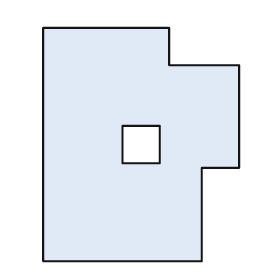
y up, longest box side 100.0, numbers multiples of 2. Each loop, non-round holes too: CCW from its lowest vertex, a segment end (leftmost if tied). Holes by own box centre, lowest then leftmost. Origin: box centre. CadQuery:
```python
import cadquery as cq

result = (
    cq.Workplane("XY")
    .moveTo(-42.0, -50.0)
    .lineTo(26.0, -50.0)
    .lineTo(26.0, -10.0)
    .lineTo(42.0, -10.0)
    .lineTo(42.0, 34.0)
    .lineTo(12.0, 34.0)
    .lineTo(12.0, 50.0)
    .lineTo(-42.0, 50.0)
    .close()
    .moveTo(-8.0, -8.0)
    .lineTo(8.0, -8.0)
    .lineTo(8.0, 8.0)
    .lineTo(-8.0, 8.0)
    .close()
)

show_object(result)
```